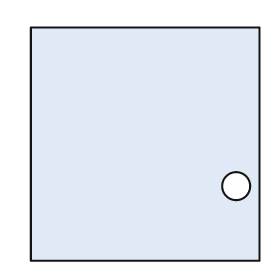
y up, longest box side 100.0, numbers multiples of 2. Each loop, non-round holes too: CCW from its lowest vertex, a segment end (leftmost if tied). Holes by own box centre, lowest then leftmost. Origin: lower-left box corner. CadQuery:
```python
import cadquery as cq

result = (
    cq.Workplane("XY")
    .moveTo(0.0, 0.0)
    .lineTo(98.0, 0.0)
    .lineTo(98.0, 100.0)
    .lineTo(0.0, 100.0)
    .close()
    .moveTo(88.0, 32.0)
    .circle(6.0)
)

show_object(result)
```